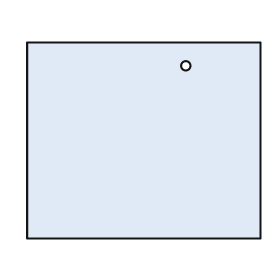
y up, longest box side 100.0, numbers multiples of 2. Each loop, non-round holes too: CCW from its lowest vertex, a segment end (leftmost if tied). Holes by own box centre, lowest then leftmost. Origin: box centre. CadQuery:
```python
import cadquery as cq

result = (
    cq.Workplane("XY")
    .moveTo(-50.0, -42.0)
    .lineTo(50.0, -42.0)
    .lineTo(50.0, 42.0)
    .lineTo(-50.0, 42.0)
    .close()
    .moveTo(18.0, 32.0)
    .circle(2.0)
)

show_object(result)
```